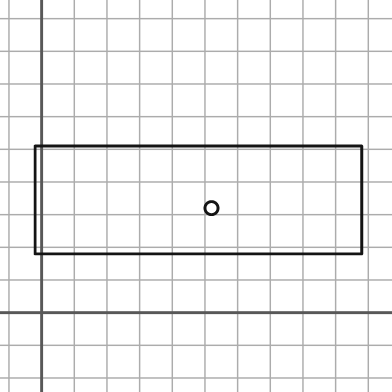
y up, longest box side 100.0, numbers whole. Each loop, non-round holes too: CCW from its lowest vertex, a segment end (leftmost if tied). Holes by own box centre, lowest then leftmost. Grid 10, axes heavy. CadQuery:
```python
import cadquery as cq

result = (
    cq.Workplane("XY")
    .moveTo(-2.0, 18.0)
    .lineTo(98.0, 18.0)
    .lineTo(98.0, 51.0)
    .lineTo(-2.0, 51.0)
    .close()
    .moveTo(52.0, 32.0)
    .circle(2.0)
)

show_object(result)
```